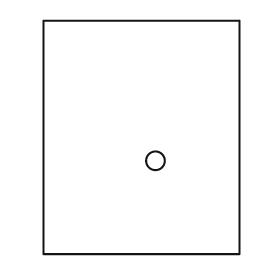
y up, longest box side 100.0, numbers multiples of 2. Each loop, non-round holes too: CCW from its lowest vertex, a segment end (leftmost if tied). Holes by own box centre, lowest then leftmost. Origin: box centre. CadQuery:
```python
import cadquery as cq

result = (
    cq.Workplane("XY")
    .moveTo(-42.0, -50.0)
    .lineTo(42.0, -50.0)
    .lineTo(42.0, 50.0)
    .lineTo(-42.0, 50.0)
    .close()
    .moveTo(6.0, -10.0)
    .circle(4.0)
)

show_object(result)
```